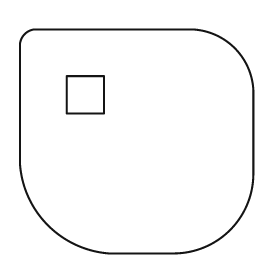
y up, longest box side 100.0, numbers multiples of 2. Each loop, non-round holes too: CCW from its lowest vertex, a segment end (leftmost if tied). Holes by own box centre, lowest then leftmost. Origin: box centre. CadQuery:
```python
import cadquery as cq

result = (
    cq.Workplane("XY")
    .moveTo(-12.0, -48.0)
    .lineTo(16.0, -48.0)
    .threePointArc((40.0, -38.0), (50.0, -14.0))
    .lineTo(50.0, 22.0)
    .threePointArc((42.0, 40.0), (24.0, 48.0))
    .lineTo(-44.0, 48.0)
    .threePointArc((-48.0, 46.0), (-50.0, 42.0))
    .lineTo(-50.0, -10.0)
    .threePointArc((-38.0, -36.0), (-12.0, -48.0))
    .close()
    .moveTo(-30.0, 12.0)
    .lineTo(-14.0, 12.0)
    .lineTo(-14.0, 28.0)
    .lineTo(-30.0, 28.0)
    .close()
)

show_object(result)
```